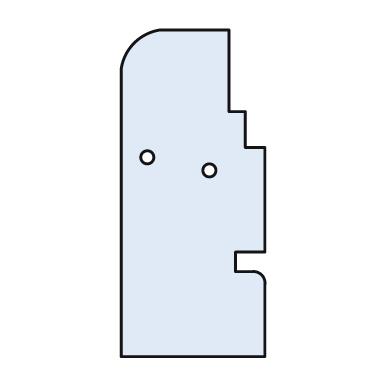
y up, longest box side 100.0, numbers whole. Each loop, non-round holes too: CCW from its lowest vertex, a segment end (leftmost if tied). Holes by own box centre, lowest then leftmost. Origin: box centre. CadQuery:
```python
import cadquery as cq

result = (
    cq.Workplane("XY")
    .moveTo(-22.0, -50.0)
    .lineTo(22.0, -50.0)
    .lineTo(22.0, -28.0)
    .threePointArc((21.0, -25.0), (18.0, -24.0))
    .lineTo(13.0, -24.0)
    .lineTo(13.0, -18.0)
    .lineTo(22.0, -18.0)
    .lineTo(22.0, 14.0)
    .lineTo(16.0, 14.0)
    .lineTo(16.0, 25.0)
    .lineTo(11.0, 25.0)
    .lineTo(11.0, 50.0)
    .lineTo(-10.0, 50.0)
    .threePointArc((-18.0, 46.0), (-22.0, 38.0))
    .close()
    .moveTo(5.0, 7.0)
    .circle(2.0)
    .moveTo(-14.0, 11.0)
    .circle(2.0)
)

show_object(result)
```